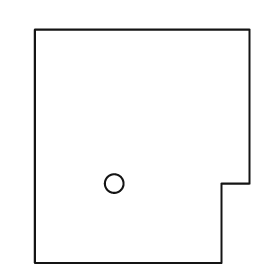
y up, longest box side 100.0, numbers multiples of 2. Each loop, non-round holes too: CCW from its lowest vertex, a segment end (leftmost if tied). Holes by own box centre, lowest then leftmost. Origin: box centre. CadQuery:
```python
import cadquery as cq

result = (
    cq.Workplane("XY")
    .moveTo(-46.0, -50.0)
    .lineTo(34.0, -50.0)
    .lineTo(34.0, -16.0)
    .lineTo(46.0, -16.0)
    .lineTo(46.0, 50.0)
    .lineTo(-46.0, 50.0)
    .close()
    .moveTo(-12.0, -16.0)
    .circle(4.0)
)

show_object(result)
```